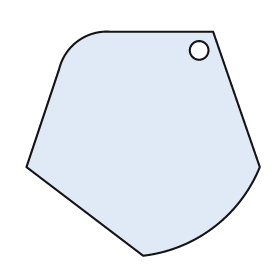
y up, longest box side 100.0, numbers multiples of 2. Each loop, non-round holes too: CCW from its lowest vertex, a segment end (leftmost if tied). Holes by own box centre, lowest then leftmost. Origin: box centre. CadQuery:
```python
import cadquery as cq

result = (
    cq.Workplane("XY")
    .moveTo(0.0, -48.0)
    .threePointArc((30.0, -36.0), (50.0, -10.0))
    .lineTo(30.0, 48.0)
    .lineTo(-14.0, 48.0)
    .threePointArc((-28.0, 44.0), (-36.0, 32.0))
    .lineTo(-50.0, -10.0)
    .close()
    .moveTo(24.0, 40.0)
    .circle(4.0)
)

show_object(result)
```